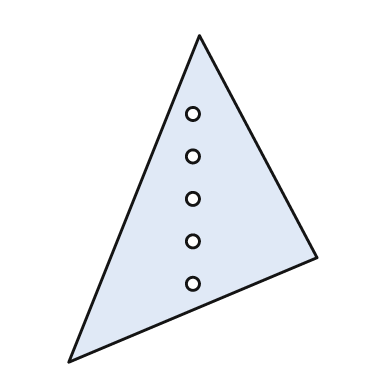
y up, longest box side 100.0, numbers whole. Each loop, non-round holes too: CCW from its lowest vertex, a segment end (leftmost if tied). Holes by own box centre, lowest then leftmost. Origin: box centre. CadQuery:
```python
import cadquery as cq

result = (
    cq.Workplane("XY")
    .moveTo(-38.0, -50.0)
    .lineTo(38.0, -18.0)
    .lineTo(2.0, 50.0)
    .close()
    .moveTo(0.0, -26.0)
    .circle(2.0)
    .moveTo(0.0, -13.0)
    .circle(2.0)
    .moveTo(0.0, 0.0)
    .circle(2.0)
    .moveTo(0.0, 13.0)
    .circle(2.0)
    .moveTo(0.0, 26.0)
    .circle(2.0)
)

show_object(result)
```